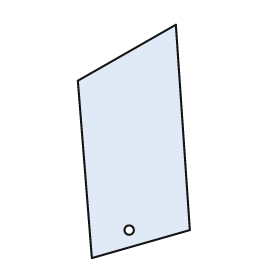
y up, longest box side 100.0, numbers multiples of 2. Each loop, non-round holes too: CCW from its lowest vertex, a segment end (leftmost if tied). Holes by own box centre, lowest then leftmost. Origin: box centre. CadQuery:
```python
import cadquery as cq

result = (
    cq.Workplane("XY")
    .moveTo(-18.0, -50.0)
    .lineTo(24.0, -38.0)
    .lineTo(18.0, 50.0)
    .lineTo(-24.0, 26.0)
    .close()
    .moveTo(-2.0, -38.0)
    .circle(2.0)
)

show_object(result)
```